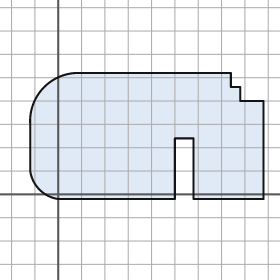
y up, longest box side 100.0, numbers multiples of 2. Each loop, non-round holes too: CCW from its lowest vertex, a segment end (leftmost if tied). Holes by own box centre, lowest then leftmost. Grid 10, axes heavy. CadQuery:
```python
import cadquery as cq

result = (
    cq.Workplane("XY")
    .moveTo(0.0, -2.0)
    .lineTo(50.0, -2.0)
    .lineTo(50.0, 24.0)
    .lineTo(58.0, 24.0)
    .lineTo(58.0, -2.0)
    .lineTo(88.0, -2.0)
    .lineTo(88.0, 40.0)
    .lineTo(78.0, 40.0)
    .lineTo(78.0, 46.0)
    .lineTo(74.0, 46.0)
    .lineTo(74.0, 52.0)
    .lineTo(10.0, 52.0)
    .threePointArc((-6.0, 46.0), (-12.0, 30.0))
    .lineTo(-12.0, 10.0)
    .threePointArc((-8.0, 2.0), (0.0, -2.0))
    .close()
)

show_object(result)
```